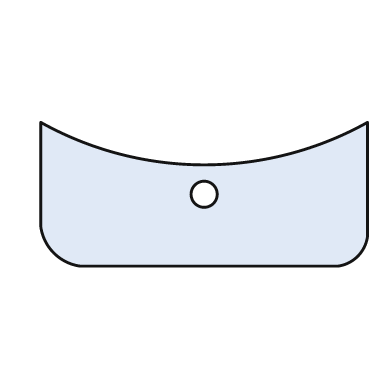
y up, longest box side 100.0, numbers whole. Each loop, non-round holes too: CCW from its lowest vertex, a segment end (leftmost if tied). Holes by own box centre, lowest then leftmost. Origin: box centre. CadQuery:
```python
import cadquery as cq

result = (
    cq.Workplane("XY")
    .moveTo(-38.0, -22.0)
    .lineTo(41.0, -22.0)
    .threePointArc((47.0, -19.0), (50.0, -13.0))
    .lineTo(50.0, 22.0)
    .threePointArc((0.0, 9.0), (-50.0, 22.0))
    .lineTo(-50.0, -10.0)
    .threePointArc((-46.0, -18.0), (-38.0, -22.0))
    .close()
    .moveTo(0.0, 0.0)
    .circle(4.0)
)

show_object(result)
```